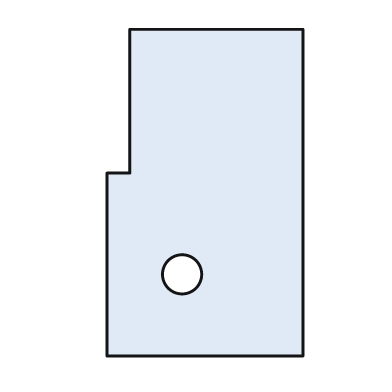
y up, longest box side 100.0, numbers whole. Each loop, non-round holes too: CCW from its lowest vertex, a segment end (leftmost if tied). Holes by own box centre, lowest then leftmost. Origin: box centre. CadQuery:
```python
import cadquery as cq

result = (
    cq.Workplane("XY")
    .moveTo(-30.0, -50.0)
    .lineTo(30.0, -50.0)
    .lineTo(30.0, 50.0)
    .lineTo(-23.0, 50.0)
    .lineTo(-23.0, 6.0)
    .lineTo(-30.0, 6.0)
    .close()
    .moveTo(-7.0, -25.0)
    .circle(6.0)
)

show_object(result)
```